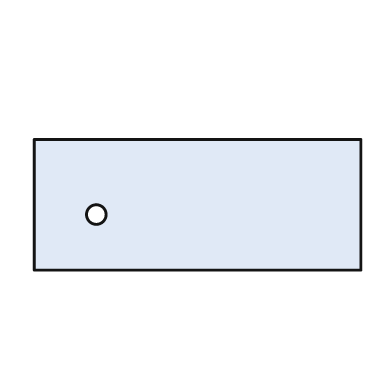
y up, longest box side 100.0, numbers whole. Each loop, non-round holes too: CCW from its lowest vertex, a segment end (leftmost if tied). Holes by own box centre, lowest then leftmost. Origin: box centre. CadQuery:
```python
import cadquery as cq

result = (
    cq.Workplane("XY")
    .moveTo(-50.0, -20.0)
    .lineTo(50.0, -20.0)
    .lineTo(50.0, 20.0)
    .lineTo(-50.0, 20.0)
    .close()
    .moveTo(-31.0, -3.0)
    .circle(3.0)
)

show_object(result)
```